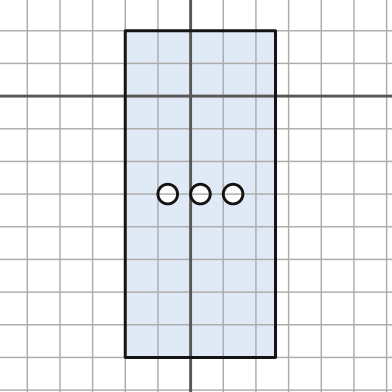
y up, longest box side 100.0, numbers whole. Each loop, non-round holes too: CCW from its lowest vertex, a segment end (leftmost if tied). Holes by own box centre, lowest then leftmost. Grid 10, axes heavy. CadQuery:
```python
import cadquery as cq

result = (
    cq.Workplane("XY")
    .moveTo(-20.0, -80.0)
    .lineTo(26.0, -80.0)
    .lineTo(26.0, 20.0)
    .lineTo(-20.0, 20.0)
    .close()
    .moveTo(-7.0, -30.0)
    .circle(3.0)
    .moveTo(3.0, -30.0)
    .circle(3.0)
    .moveTo(13.0, -30.0)
    .circle(3.0)
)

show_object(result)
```